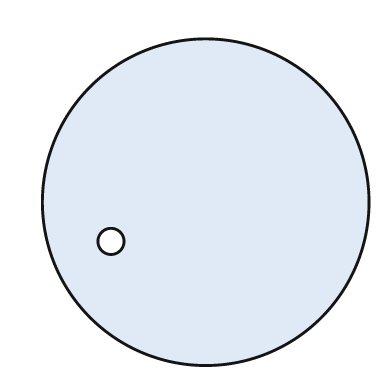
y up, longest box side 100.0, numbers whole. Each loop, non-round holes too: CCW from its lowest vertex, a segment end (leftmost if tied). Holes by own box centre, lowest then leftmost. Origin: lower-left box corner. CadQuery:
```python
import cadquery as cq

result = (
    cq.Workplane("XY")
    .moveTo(50.0, 50.0)
    .circle(50.0)
    .moveTo(21.0, 38.0)
    .circle(4.0)
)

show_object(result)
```